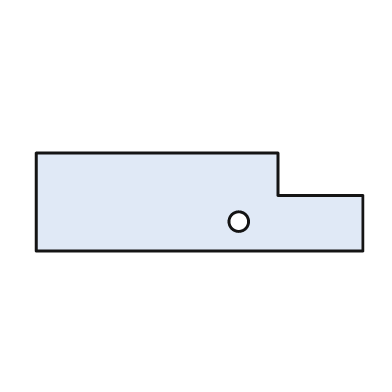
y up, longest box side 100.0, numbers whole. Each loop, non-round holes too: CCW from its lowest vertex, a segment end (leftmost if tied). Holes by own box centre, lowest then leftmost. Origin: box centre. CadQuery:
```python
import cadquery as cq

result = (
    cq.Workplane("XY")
    .moveTo(-50.0, -15.0)
    .lineTo(50.0, -15.0)
    .lineTo(50.0, 2.0)
    .lineTo(24.0, 2.0)
    .lineTo(24.0, 15.0)
    .lineTo(-50.0, 15.0)
    .close()
    .moveTo(12.0, -6.0)
    .circle(3.0)
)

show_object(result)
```